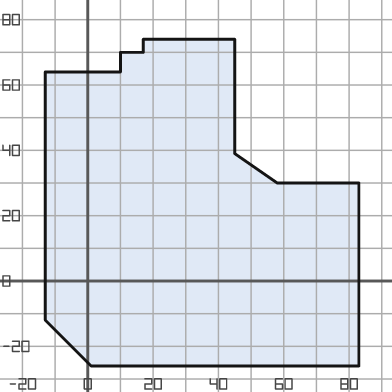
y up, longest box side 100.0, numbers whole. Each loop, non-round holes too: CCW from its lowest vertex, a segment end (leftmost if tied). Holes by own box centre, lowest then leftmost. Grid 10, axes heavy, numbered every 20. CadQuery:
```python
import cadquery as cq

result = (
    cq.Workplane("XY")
    .moveTo(1.0, -26.0)
    .lineTo(83.0, -26.0)
    .lineTo(83.0, 30.0)
    .lineTo(58.0, 30.0)
    .lineTo(45.0, 39.0)
    .lineTo(45.0, 74.0)
    .lineTo(17.0, 74.0)
    .lineTo(17.0, 70.0)
    .lineTo(10.0, 70.0)
    .lineTo(10.0, 64.0)
    .lineTo(-13.0, 64.0)
    .lineTo(-13.0, -12.0)
    .close()
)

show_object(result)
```